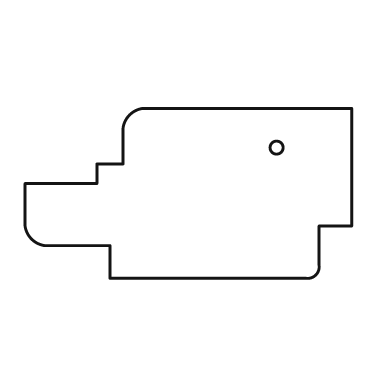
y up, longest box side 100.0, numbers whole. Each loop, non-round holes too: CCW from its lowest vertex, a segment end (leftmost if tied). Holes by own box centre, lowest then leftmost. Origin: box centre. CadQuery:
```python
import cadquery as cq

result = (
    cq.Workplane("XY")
    .moveTo(-24.0, -26.0)
    .lineTo(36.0, -26.0)
    .threePointArc((39.0, -25.0), (40.0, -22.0))
    .lineTo(40.0, -10.0)
    .lineTo(50.0, -10.0)
    .lineTo(50.0, 26.0)
    .lineTo(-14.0, 26.0)
    .threePointArc((-18.0, 24.0), (-20.0, 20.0))
    .lineTo(-20.0, 9.0)
    .lineTo(-28.0, 9.0)
    .lineTo(-28.0, 3.0)
    .lineTo(-50.0, 3.0)
    .lineTo(-50.0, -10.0)
    .threePointArc((-48.0, -14.0), (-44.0, -16.0))
    .lineTo(-24.0, -16.0)
    .close()
    .moveTo(27.0, 14.0)
    .circle(2.0)
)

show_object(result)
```